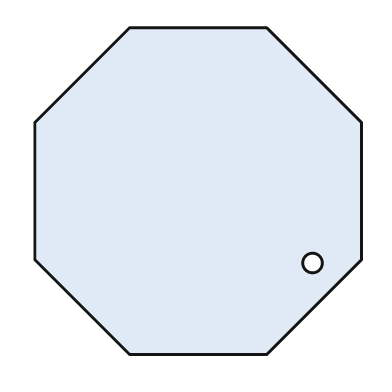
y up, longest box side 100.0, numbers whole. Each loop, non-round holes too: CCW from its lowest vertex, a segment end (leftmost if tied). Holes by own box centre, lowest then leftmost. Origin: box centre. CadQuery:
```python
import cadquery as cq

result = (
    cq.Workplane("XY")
    .moveTo(-21.0, -50.0)
    .lineTo(21.0, -50.0)
    .lineTo(50.0, -21.0)
    .lineTo(50.0, 21.0)
    .lineTo(21.0, 50.0)
    .lineTo(-21.0, 50.0)
    .lineTo(-50.0, 21.0)
    .lineTo(-50.0, -21.0)
    .close()
    .moveTo(35.0, -22.0)
    .circle(3.0)
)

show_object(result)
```